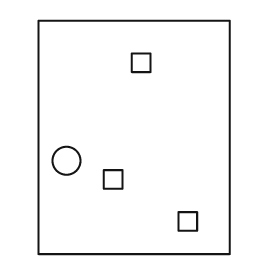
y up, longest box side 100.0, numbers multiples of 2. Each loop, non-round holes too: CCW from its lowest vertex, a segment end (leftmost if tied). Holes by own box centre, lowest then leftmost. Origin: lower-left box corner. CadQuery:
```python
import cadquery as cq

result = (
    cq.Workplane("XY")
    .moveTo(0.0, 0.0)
    .lineTo(82.0, 0.0)
    .lineTo(82.0, 100.0)
    .lineTo(0.0, 100.0)
    .close()
    .moveTo(60.0, 10.0)
    .lineTo(68.0, 10.0)
    .lineTo(68.0, 18.0)
    .lineTo(60.0, 18.0)
    .close()
    .moveTo(28.0, 28.0)
    .lineTo(36.0, 28.0)
    .lineTo(36.0, 36.0)
    .lineTo(28.0, 36.0)
    .close()
    .moveTo(12.0, 40.0)
    .circle(6.0)
    .moveTo(40.0, 78.0)
    .lineTo(48.0, 78.0)
    .lineTo(48.0, 86.0)
    .lineTo(40.0, 86.0)
    .close()
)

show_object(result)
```